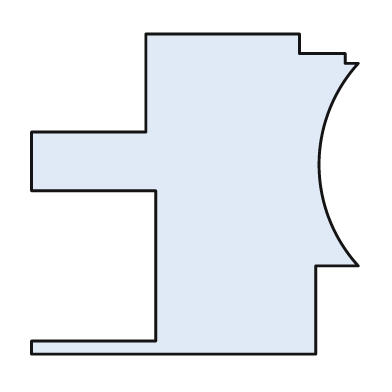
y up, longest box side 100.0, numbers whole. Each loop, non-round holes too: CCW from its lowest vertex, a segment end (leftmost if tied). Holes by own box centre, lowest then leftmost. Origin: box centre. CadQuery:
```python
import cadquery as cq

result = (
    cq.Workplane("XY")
    .moveTo(-50.0, -49.0)
    .lineTo(37.0, -49.0)
    .lineTo(37.0, -22.0)
    .lineTo(50.0, -22.0)
    .threePointArc((38.0, 9.0), (50.0, 40.0))
    .lineTo(46.0, 40.0)
    .lineTo(46.0, 43.0)
    .lineTo(32.0, 43.0)
    .lineTo(32.0, 49.0)
    .lineTo(-15.0, 49.0)
    .lineTo(-15.0, 19.0)
    .lineTo(-50.0, 19.0)
    .lineTo(-50.0, 1.0)
    .lineTo(-12.0, 1.0)
    .lineTo(-12.0, -45.0)
    .lineTo(-50.0, -45.0)
    .close()
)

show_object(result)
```